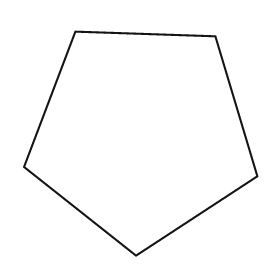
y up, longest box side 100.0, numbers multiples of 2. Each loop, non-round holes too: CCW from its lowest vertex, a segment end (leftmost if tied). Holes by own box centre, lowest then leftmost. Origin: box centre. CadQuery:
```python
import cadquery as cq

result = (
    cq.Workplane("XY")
    .moveTo(-2.0, -48.0)
    .lineTo(50.0, -14.0)
    .lineTo(32.0, 46.0)
    .lineTo(-28.0, 48.0)
    .lineTo(-50.0, -10.0)
    .close()
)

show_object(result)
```